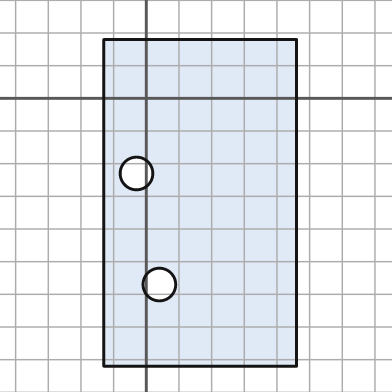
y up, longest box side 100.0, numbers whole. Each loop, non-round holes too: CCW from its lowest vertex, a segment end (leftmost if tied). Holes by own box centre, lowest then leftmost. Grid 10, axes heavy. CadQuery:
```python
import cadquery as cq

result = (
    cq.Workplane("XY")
    .moveTo(-13.0, -82.0)
    .lineTo(46.0, -82.0)
    .lineTo(46.0, 18.0)
    .lineTo(-13.0, 18.0)
    .close()
    .moveTo(4.0, -57.0)
    .circle(5.0)
    .moveTo(-3.0, -23.0)
    .circle(5.0)
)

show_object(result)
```